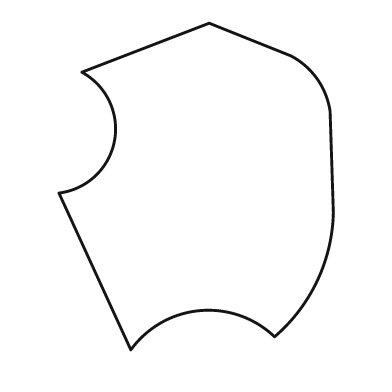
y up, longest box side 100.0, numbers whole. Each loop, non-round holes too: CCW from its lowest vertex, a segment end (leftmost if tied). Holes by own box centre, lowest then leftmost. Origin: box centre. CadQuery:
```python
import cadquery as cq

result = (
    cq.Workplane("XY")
    .moveTo(-20.0, -50.0)
    .threePointArc((1.0, -38.0), (24.0, -46.0))
    .threePointArc((37.0, -29.0), (42.0, -8.0))
    .lineTo(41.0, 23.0)
    .threePointArc((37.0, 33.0), (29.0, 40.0))
    .lineTo(4.0, 50.0)
    .lineTo(-35.0, 35.0)
    .threePointArc((-25.0, 14.0), (-42.0, -2.0))
    .close()
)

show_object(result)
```